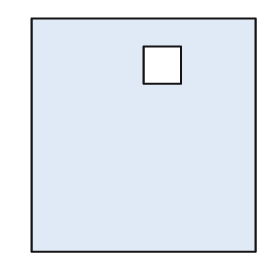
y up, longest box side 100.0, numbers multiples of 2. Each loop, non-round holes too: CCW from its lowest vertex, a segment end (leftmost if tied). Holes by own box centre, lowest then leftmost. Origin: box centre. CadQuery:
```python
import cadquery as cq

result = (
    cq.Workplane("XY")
    .moveTo(-48.0, -50.0)
    .lineTo(48.0, -50.0)
    .lineTo(48.0, 50.0)
    .lineTo(-48.0, 50.0)
    .close()
    .moveTo(0.0, 22.0)
    .lineTo(16.0, 22.0)
    .lineTo(16.0, 38.0)
    .lineTo(0.0, 38.0)
    .close()
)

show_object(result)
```